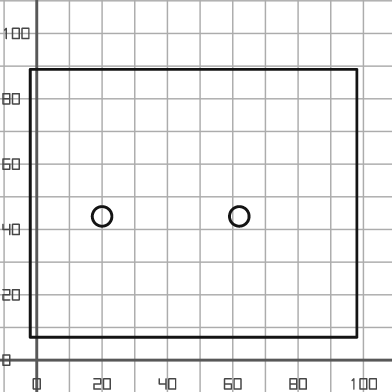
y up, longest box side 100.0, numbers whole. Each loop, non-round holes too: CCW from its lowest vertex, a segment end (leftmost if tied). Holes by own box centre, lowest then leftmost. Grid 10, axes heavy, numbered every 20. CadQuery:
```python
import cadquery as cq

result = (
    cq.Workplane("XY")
    .moveTo(-2.0, 7.0)
    .lineTo(98.0, 7.0)
    .lineTo(98.0, 89.0)
    .lineTo(-2.0, 89.0)
    .close()
    .moveTo(20.0, 44.0)
    .circle(3.0)
    .moveTo(62.0, 44.0)
    .circle(3.0)
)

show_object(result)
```